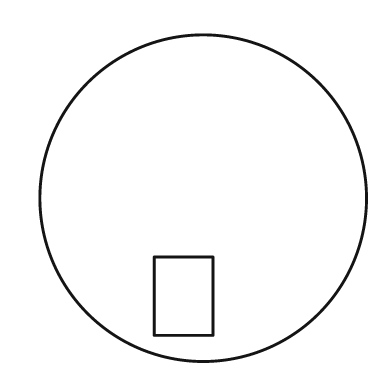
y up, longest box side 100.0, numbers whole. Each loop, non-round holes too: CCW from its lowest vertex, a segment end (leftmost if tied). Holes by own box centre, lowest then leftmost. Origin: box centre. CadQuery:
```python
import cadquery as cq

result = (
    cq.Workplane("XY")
    .moveTo(0.0, 0.0)
    .circle(50.0)
    .moveTo(-15.0, -42.0)
    .lineTo(3.0, -42.0)
    .lineTo(3.0, -18.0)
    .lineTo(-15.0, -18.0)
    .close()
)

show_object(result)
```